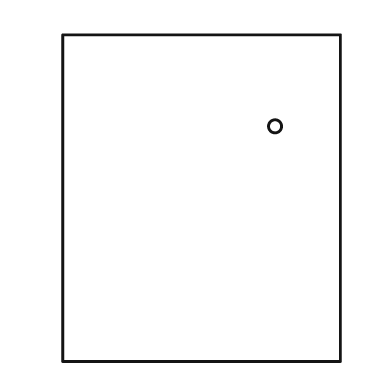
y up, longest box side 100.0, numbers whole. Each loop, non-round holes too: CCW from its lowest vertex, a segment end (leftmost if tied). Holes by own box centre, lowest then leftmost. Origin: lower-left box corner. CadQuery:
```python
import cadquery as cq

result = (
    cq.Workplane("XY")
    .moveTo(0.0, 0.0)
    .lineTo(85.0, 0.0)
    .lineTo(85.0, 100.0)
    .lineTo(0.0, 100.0)
    .close()
    .moveTo(65.0, 72.0)
    .circle(2.0)
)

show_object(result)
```